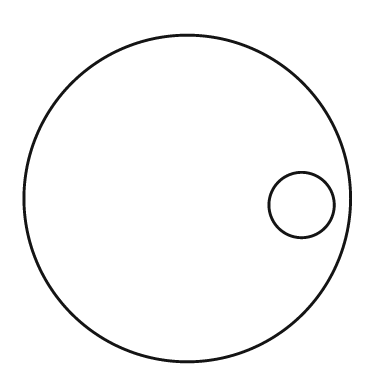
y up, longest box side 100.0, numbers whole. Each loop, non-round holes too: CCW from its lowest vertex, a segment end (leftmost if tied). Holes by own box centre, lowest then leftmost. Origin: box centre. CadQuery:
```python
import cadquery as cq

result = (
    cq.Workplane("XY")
    .moveTo(0.0, 0.0)
    .circle(50.0)
    .moveTo(35.0, -2.0)
    .circle(10.0)
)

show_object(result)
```